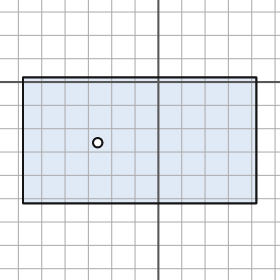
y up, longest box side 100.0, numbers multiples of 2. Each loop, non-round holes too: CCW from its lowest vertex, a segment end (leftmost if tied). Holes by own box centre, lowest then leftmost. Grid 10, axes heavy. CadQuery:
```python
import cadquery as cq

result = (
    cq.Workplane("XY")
    .moveTo(-58.0, -52.0)
    .lineTo(42.0, -52.0)
    .lineTo(42.0, 2.0)
    .lineTo(-58.0, 2.0)
    .close()
    .moveTo(-26.0, -26.0)
    .circle(2.0)
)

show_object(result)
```